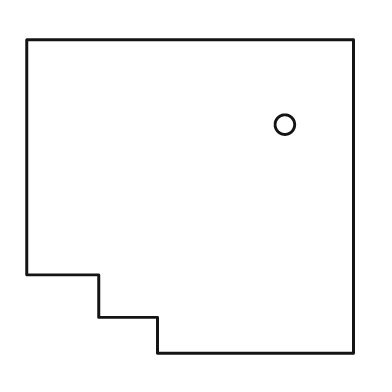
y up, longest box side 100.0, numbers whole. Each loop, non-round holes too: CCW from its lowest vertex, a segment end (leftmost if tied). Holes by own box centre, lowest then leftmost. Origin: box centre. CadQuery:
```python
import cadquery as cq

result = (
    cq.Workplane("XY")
    .moveTo(-10.0, -48.0)
    .lineTo(50.0, -48.0)
    .lineTo(50.0, 48.0)
    .lineTo(-50.0, 48.0)
    .lineTo(-50.0, -24.0)
    .lineTo(-28.0, -24.0)
    .lineTo(-28.0, -37.0)
    .lineTo(-10.0, -37.0)
    .close()
    .moveTo(29.0, 22.0)
    .circle(3.0)
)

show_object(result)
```